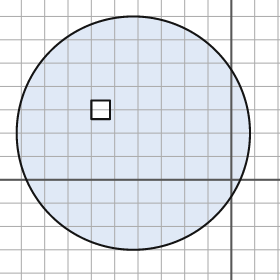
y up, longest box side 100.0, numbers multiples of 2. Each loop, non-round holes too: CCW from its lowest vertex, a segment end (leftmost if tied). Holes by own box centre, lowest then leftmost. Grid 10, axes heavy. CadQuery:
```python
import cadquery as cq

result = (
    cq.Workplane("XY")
    .moveTo(-42.0, 20.0)
    .circle(50.0)
    .moveTo(-60.0, 26.0)
    .lineTo(-52.0, 26.0)
    .lineTo(-52.0, 34.0)
    .lineTo(-60.0, 34.0)
    .close()
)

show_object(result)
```